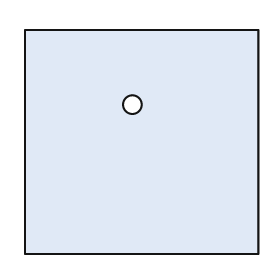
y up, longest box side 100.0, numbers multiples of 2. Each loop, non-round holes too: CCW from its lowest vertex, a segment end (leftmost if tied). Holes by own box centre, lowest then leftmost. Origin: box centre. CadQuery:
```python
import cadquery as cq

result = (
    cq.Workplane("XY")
    .moveTo(-50.0, -48.0)
    .lineTo(50.0, -48.0)
    .lineTo(50.0, 48.0)
    .lineTo(-50.0, 48.0)
    .close()
    .moveTo(-4.0, 16.0)
    .circle(4.0)
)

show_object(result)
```